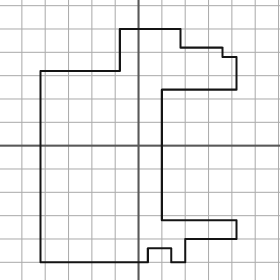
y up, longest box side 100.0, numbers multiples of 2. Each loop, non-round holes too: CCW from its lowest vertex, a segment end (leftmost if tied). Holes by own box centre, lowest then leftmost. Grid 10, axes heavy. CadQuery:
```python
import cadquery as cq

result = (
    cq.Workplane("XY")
    .moveTo(-42.0, -50.0)
    .lineTo(4.0, -50.0)
    .lineTo(4.0, -44.0)
    .lineTo(14.0, -44.0)
    .lineTo(14.0, -50.0)
    .lineTo(20.0, -50.0)
    .lineTo(20.0, -40.0)
    .lineTo(42.0, -40.0)
    .lineTo(42.0, -32.0)
    .lineTo(10.0, -32.0)
    .lineTo(10.0, 24.0)
    .lineTo(42.0, 24.0)
    .lineTo(42.0, 38.0)
    .lineTo(36.0, 38.0)
    .lineTo(36.0, 42.0)
    .lineTo(18.0, 42.0)
    .lineTo(18.0, 50.0)
    .lineTo(-8.0, 50.0)
    .lineTo(-8.0, 32.0)
    .lineTo(-42.0, 32.0)
    .close()
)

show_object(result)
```